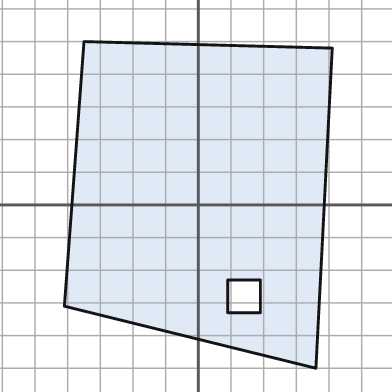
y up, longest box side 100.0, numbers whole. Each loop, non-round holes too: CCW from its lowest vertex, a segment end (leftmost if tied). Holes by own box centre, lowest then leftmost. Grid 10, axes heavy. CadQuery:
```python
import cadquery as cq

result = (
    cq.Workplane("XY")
    .moveTo(36.0, -50.0)
    .lineTo(41.0, 48.0)
    .lineTo(-35.0, 50.0)
    .lineTo(-41.0, -31.0)
    .close()
    .moveTo(9.0, -33.0)
    .lineTo(19.0, -33.0)
    .lineTo(19.0, -23.0)
    .lineTo(9.0, -23.0)
    .close()
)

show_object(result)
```